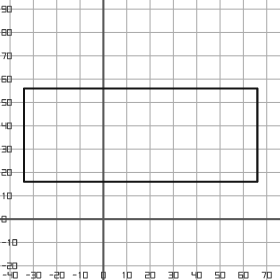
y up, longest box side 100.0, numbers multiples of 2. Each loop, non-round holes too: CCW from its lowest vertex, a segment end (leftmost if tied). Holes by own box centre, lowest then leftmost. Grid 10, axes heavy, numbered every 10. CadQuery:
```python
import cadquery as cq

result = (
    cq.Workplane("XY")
    .moveTo(-34.0, 16.0)
    .lineTo(66.0, 16.0)
    .lineTo(66.0, 56.0)
    .lineTo(-34.0, 56.0)
    .close()
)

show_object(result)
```